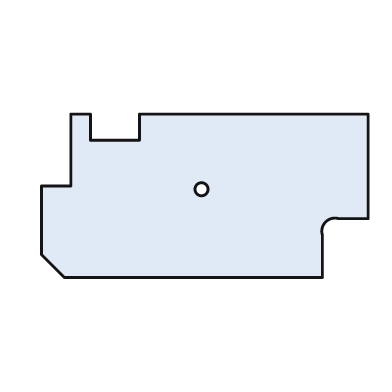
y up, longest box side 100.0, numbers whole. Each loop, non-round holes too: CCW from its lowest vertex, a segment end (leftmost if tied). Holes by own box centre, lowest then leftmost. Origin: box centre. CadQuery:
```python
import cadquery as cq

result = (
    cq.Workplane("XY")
    .moveTo(-43.0, -25.0)
    .lineTo(36.0, -25.0)
    .lineTo(36.0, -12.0)
    .threePointArc((37.0, -8.0), (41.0, -7.0))
    .lineTo(50.0, -7.0)
    .lineTo(50.0, 25.0)
    .lineTo(-20.0, 25.0)
    .lineTo(-20.0, 17.0)
    .lineTo(-35.0, 17.0)
    .lineTo(-35.0, 25.0)
    .lineTo(-41.0, 25.0)
    .lineTo(-41.0, 3.0)
    .lineTo(-50.0, 3.0)
    .lineTo(-50.0, -18.0)
    .close()
    .moveTo(-1.0, 2.0)
    .circle(2.0)
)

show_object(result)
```